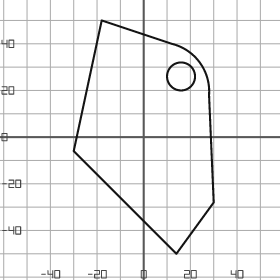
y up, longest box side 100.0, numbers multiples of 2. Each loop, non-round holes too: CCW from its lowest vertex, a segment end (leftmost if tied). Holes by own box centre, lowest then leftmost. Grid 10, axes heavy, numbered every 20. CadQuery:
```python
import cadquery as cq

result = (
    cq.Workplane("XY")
    .moveTo(14.0, -50.0)
    .lineTo(30.0, -28.0)
    .lineTo(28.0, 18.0)
    .threePointArc((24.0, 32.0), (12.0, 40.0))
    .lineTo(-18.0, 50.0)
    .lineTo(-30.0, -6.0)
    .close()
    .moveTo(16.0, 26.0)
    .circle(6.0)
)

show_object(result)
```